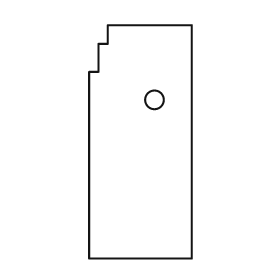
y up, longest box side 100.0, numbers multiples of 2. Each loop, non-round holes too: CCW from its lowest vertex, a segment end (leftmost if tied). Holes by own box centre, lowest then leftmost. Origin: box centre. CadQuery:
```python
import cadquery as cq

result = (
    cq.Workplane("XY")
    .moveTo(-22.0, -50.0)
    .lineTo(22.0, -50.0)
    .lineTo(22.0, 50.0)
    .lineTo(-14.0, 50.0)
    .lineTo(-14.0, 42.0)
    .lineTo(-18.0, 42.0)
    .lineTo(-18.0, 30.0)
    .lineTo(-22.0, 30.0)
    .close()
    .moveTo(6.0, 18.0)
    .circle(4.0)
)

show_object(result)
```